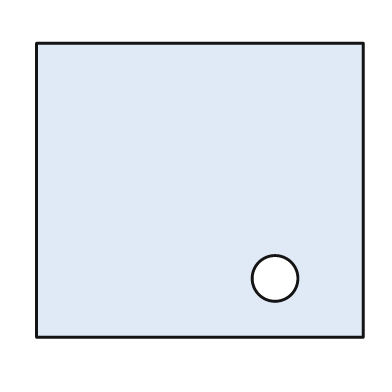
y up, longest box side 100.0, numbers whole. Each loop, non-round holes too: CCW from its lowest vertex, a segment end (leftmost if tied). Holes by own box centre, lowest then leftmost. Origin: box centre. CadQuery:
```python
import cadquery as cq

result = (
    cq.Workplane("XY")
    .moveTo(-50.0, -45.0)
    .lineTo(50.0, -45.0)
    .lineTo(50.0, 45.0)
    .lineTo(-50.0, 45.0)
    .close()
    .moveTo(23.0, -27.0)
    .circle(7.0)
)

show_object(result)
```